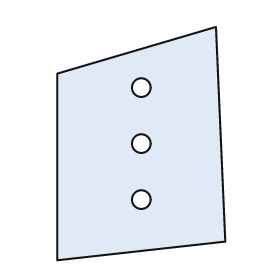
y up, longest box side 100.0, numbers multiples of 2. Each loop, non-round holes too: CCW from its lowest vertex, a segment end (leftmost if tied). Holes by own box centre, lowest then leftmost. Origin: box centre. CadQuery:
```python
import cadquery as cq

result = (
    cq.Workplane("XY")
    .moveTo(-36.0, -50.0)
    .lineTo(36.0, -42.0)
    .lineTo(32.0, 50.0)
    .lineTo(-36.0, 30.0)
    .close()
    .moveTo(0.0, -24.0)
    .circle(4.0)
    .moveTo(0.0, 0.0)
    .circle(4.0)
    .moveTo(0.0, 24.0)
    .circle(4.0)
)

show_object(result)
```